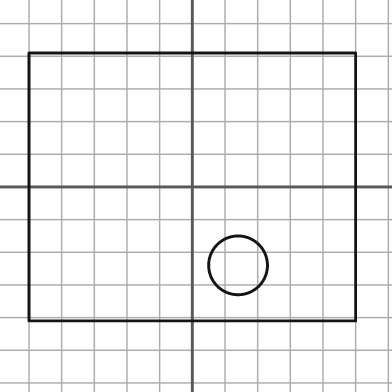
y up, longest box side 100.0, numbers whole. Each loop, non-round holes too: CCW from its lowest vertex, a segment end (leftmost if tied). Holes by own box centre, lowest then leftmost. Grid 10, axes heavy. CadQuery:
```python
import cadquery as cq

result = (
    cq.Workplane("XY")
    .moveTo(-50.0, -41.0)
    .lineTo(50.0, -41.0)
    .lineTo(50.0, 41.0)
    .lineTo(-50.0, 41.0)
    .close()
    .moveTo(14.0, -24.0)
    .circle(9.0)
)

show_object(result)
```